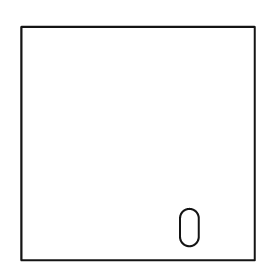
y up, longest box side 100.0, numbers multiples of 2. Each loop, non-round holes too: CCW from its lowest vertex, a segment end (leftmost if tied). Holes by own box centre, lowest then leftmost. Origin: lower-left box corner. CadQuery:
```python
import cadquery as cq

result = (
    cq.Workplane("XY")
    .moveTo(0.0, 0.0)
    .lineTo(100.0, 0.0)
    .lineTo(100.0, 100.0)
    .lineTo(0.0, 100.0)
    .close()
    .moveTo(68.0, 10.0)
    .threePointArc((72.0, 6.0), (76.0, 10.0))
    .lineTo(76.0, 18.0)
    .threePointArc((72.0, 22.0), (68.0, 18.0))
    .close()
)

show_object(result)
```